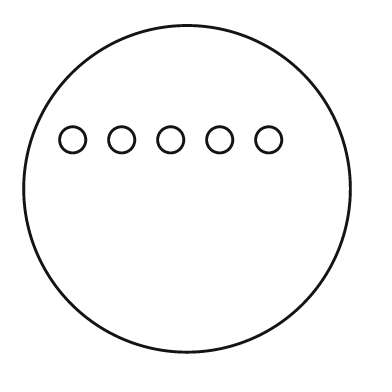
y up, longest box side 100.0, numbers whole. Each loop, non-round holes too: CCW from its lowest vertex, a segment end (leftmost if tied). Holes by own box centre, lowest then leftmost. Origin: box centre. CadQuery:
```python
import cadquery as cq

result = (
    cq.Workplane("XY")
    .moveTo(0.0, 0.0)
    .circle(50.0)
    .moveTo(-35.0, 15.0)
    .circle(4.0)
    .moveTo(-20.0, 15.0)
    .circle(4.0)
    .moveTo(-5.0, 15.0)
    .circle(4.0)
    .moveTo(10.0, 15.0)
    .circle(4.0)
    .moveTo(25.0, 15.0)
    .circle(4.0)
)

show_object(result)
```